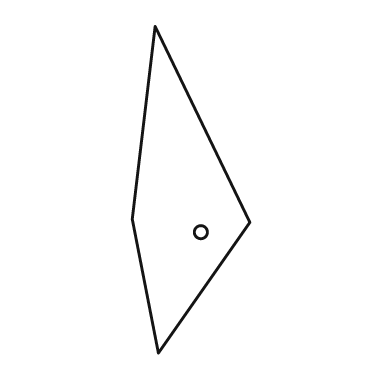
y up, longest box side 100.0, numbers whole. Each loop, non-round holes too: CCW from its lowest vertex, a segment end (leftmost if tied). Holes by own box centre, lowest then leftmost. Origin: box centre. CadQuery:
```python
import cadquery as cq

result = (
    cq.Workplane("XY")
    .moveTo(-10.0, -50.0)
    .lineTo(18.0, -10.0)
    .lineTo(-11.0, 50.0)
    .lineTo(-18.0, -9.0)
    .close()
    .moveTo(3.0, -13.0)
    .circle(2.0)
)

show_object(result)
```